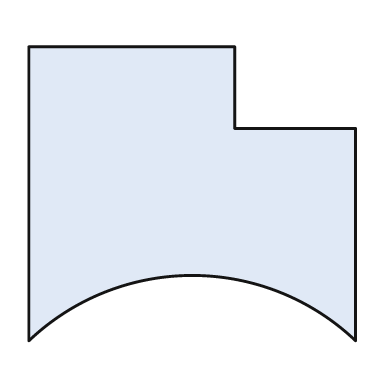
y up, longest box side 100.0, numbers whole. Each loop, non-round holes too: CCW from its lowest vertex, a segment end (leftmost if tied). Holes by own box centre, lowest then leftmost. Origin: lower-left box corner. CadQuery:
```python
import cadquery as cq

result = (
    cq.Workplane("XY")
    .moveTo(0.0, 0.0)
    .threePointArc((50.0, 20.0), (100.0, 0.0))
    .lineTo(100.0, 65.0)
    .lineTo(63.0, 65.0)
    .lineTo(63.0, 90.0)
    .lineTo(0.0, 90.0)
    .close()
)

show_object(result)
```